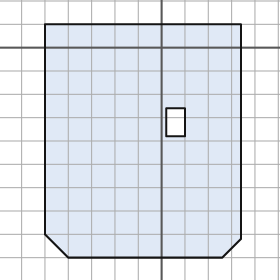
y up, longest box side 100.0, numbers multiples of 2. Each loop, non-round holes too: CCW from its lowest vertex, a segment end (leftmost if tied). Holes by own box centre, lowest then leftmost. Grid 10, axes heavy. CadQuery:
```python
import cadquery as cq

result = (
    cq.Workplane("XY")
    .moveTo(-40.0, -90.0)
    .lineTo(26.0, -90.0)
    .lineTo(34.0, -82.0)
    .lineTo(34.0, 10.0)
    .lineTo(-50.0, 10.0)
    .lineTo(-50.0, -80.0)
    .close()
    .moveTo(2.0, -38.0)
    .lineTo(10.0, -38.0)
    .lineTo(10.0, -26.0)
    .lineTo(2.0, -26.0)
    .close()
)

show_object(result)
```